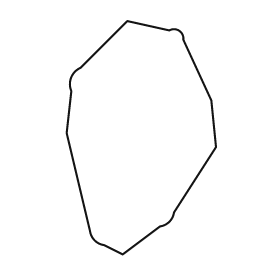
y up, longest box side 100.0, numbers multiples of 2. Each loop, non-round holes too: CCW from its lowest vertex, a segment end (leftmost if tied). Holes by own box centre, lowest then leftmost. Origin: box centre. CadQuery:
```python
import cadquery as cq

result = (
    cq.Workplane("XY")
    .moveTo(-8.0, -50.0)
    .lineTo(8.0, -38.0)
    .threePointArc((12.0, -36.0), (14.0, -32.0))
    .lineTo(32.0, -4.0)
    .lineTo(30.0, 16.0)
    .lineTo(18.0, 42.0)
    .threePointArc((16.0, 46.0), (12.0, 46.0))
    .lineTo(-6.0, 50.0)
    .lineTo(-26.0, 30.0)
    .threePointArc((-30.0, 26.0), (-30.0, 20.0))
    .lineTo(-32.0, 2.0)
    .lineTo(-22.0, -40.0)
    .threePointArc((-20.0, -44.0), (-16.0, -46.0))
    .close()
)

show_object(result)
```